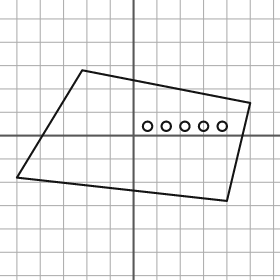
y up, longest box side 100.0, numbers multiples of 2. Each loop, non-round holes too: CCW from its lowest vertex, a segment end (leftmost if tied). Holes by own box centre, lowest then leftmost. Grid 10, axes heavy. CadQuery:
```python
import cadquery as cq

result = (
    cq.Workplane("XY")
    .moveTo(40.0, -28.0)
    .lineTo(50.0, 14.0)
    .lineTo(-22.0, 28.0)
    .lineTo(-50.0, -18.0)
    .close()
    .moveTo(6.0, 4.0)
    .circle(2.0)
    .moveTo(14.0, 4.0)
    .circle(2.0)
    .moveTo(22.0, 4.0)
    .circle(2.0)
    .moveTo(30.0, 4.0)
    .circle(2.0)
    .moveTo(38.0, 4.0)
    .circle(2.0)
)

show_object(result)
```